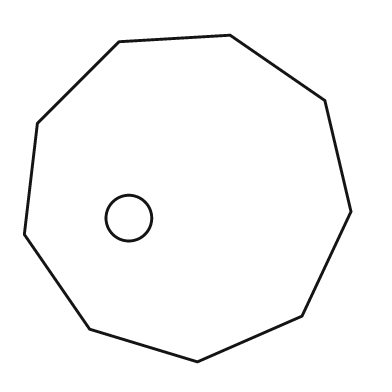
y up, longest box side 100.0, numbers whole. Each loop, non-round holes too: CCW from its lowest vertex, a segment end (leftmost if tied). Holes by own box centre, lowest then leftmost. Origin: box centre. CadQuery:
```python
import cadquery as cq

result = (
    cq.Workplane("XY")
    .moveTo(3.0, -50.0)
    .lineTo(35.0, -36.0)
    .lineTo(50.0, -4.0)
    .lineTo(42.0, 30.0)
    .lineTo(13.0, 50.0)
    .lineTo(-21.0, 48.0)
    .lineTo(-46.0, 23.0)
    .lineTo(-50.0, -11.0)
    .lineTo(-30.0, -40.0)
    .close()
    .moveTo(-18.0, -6.0)
    .circle(7.0)
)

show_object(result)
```